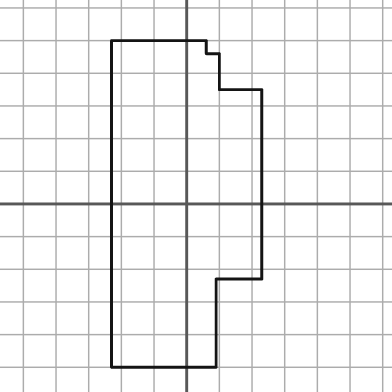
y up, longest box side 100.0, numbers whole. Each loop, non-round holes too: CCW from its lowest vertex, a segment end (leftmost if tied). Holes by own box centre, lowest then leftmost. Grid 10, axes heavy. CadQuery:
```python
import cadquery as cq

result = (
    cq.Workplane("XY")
    .moveTo(-23.0, -50.0)
    .lineTo(9.0, -50.0)
    .lineTo(9.0, -23.0)
    .lineTo(23.0, -23.0)
    .lineTo(23.0, 35.0)
    .lineTo(10.0, 35.0)
    .lineTo(10.0, 46.0)
    .lineTo(6.0, 46.0)
    .lineTo(6.0, 50.0)
    .lineTo(-23.0, 50.0)
    .close()
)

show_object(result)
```